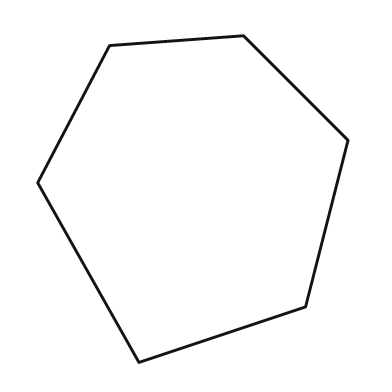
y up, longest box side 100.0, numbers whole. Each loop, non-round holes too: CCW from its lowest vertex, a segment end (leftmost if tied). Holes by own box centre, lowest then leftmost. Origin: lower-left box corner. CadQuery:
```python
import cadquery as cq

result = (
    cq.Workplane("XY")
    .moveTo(31.0, 0.0)
    .lineTo(82.0, 17.0)
    .lineTo(95.0, 68.0)
    .lineTo(63.0, 100.0)
    .lineTo(22.0, 97.0)
    .lineTo(0.0, 55.0)
    .close()
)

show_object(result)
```